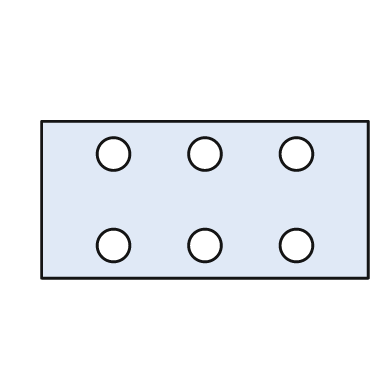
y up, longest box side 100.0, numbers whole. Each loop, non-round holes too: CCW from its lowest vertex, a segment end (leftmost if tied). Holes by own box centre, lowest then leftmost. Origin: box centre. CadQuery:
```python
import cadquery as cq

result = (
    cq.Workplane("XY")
    .moveTo(-50.0, -24.0)
    .lineTo(50.0, -24.0)
    .lineTo(50.0, 24.0)
    .lineTo(-50.0, 24.0)
    .close()
    .moveTo(-28.0, -14.0)
    .circle(5.0)
    .moveTo(0.0, -14.0)
    .circle(5.0)
    .moveTo(28.0, -14.0)
    .circle(5.0)
    .moveTo(-28.0, 14.0)
    .circle(5.0)
    .moveTo(0.0, 14.0)
    .circle(5.0)
    .moveTo(28.0, 14.0)
    .circle(5.0)
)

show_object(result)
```